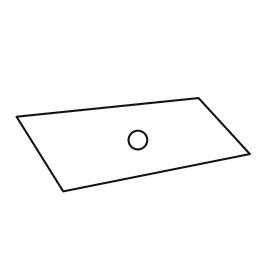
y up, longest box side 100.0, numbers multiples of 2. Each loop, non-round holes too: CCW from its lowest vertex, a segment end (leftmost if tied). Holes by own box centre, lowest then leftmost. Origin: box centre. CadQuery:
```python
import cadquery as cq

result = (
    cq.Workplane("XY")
    .moveTo(-30.0, -20.0)
    .lineTo(50.0, -4.0)
    .lineTo(28.0, 20.0)
    .lineTo(-50.0, 12.0)
    .close()
    .moveTo(2.0, 2.0)
    .circle(4.0)
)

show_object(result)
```